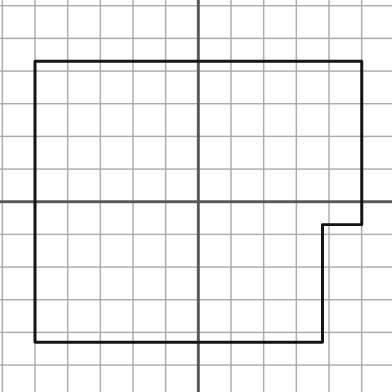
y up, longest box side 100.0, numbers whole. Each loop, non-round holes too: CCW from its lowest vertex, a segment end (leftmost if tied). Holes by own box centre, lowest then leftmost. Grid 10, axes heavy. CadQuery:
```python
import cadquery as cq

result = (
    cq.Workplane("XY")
    .moveTo(-50.0, -43.0)
    .lineTo(38.0, -43.0)
    .lineTo(38.0, -7.0)
    .lineTo(50.0, -7.0)
    .lineTo(50.0, 43.0)
    .lineTo(-50.0, 43.0)
    .close()
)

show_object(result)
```